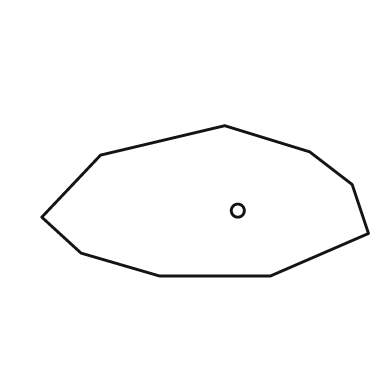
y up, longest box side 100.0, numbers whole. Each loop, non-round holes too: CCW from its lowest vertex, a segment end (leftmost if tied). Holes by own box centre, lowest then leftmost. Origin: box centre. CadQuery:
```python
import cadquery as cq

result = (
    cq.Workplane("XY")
    .moveTo(-14.0, -23.0)
    .lineTo(20.0, -23.0)
    .lineTo(50.0, -10.0)
    .lineTo(45.0, 5.0)
    .lineTo(32.0, 15.0)
    .lineTo(6.0, 23.0)
    .lineTo(-32.0, 14.0)
    .lineTo(-50.0, -5.0)
    .lineTo(-38.0, -16.0)
    .close()
    .moveTo(10.0, -3.0)
    .circle(2.0)
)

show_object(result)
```